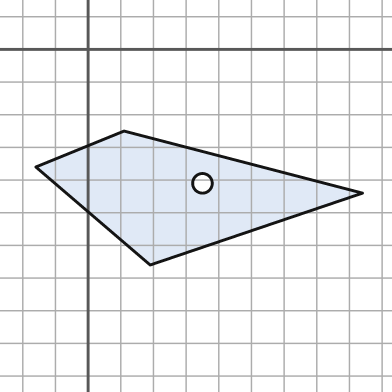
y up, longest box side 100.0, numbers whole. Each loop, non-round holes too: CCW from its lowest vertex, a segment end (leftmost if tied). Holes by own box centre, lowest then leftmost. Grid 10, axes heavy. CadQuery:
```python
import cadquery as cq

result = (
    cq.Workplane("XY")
    .moveTo(19.0, -66.0)
    .lineTo(84.0, -44.0)
    .lineTo(11.0, -25.0)
    .lineTo(-16.0, -36.0)
    .close()
    .moveTo(35.0, -41.0)
    .circle(3.0)
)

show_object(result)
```